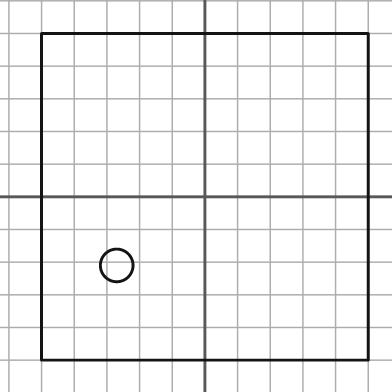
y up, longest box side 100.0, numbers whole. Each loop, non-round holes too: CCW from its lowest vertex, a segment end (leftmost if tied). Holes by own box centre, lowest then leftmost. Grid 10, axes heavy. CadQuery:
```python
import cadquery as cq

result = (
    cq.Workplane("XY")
    .moveTo(-50.0, -50.0)
    .lineTo(50.0, -50.0)
    .lineTo(50.0, 50.0)
    .lineTo(-50.0, 50.0)
    .close()
    .moveTo(-27.0, -21.0)
    .circle(5.0)
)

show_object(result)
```